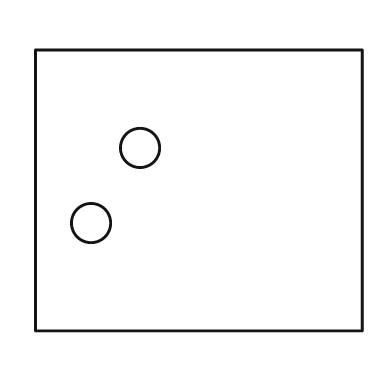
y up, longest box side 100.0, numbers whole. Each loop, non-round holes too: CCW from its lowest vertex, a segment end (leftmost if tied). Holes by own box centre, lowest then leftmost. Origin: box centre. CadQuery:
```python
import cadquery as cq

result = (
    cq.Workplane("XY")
    .moveTo(-50.0, -43.0)
    .lineTo(50.0, -43.0)
    .lineTo(50.0, 43.0)
    .lineTo(-50.0, 43.0)
    .close()
    .moveTo(-33.0, -10.0)
    .circle(6.0)
    .moveTo(-18.0, 13.0)
    .circle(6.0)
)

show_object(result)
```